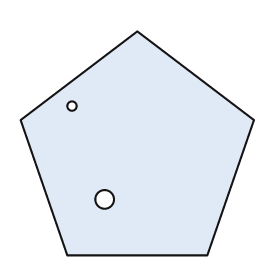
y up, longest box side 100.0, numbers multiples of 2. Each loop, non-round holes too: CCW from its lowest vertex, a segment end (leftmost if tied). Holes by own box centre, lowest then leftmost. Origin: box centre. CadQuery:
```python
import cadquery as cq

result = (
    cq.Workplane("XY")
    .moveTo(-30.0, -48.0)
    .lineTo(30.0, -48.0)
    .lineTo(50.0, 10.0)
    .lineTo(0.0, 48.0)
    .lineTo(-50.0, 10.0)
    .close()
    .moveTo(-14.0, -24.0)
    .circle(4.0)
    .moveTo(-28.0, 16.0)
    .circle(2.0)
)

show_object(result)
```